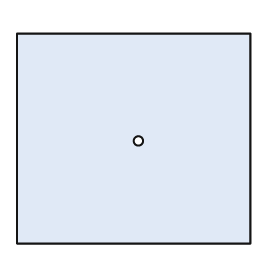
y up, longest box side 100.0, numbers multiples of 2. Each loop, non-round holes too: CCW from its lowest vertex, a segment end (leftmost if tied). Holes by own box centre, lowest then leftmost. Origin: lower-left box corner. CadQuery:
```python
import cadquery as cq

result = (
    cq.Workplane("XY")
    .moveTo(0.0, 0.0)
    .lineTo(100.0, 0.0)
    .lineTo(100.0, 90.0)
    .lineTo(0.0, 90.0)
    .close()
    .moveTo(52.0, 44.0)
    .circle(2.0)
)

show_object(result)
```